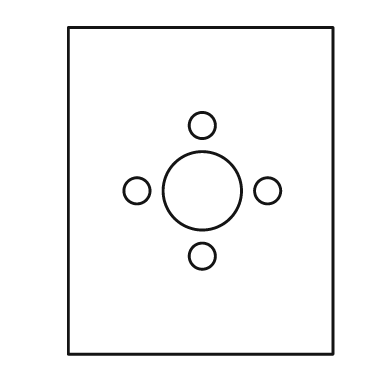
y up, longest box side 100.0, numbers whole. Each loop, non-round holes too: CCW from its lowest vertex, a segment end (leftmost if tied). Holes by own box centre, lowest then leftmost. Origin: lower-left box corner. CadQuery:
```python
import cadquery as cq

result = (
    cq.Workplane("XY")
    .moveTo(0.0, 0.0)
    .lineTo(81.0, 0.0)
    .lineTo(81.0, 100.0)
    .lineTo(0.0, 100.0)
    .close()
    .moveTo(41.0, 30.0)
    .circle(4.0)
    .moveTo(21.0, 50.0)
    .circle(4.0)
    .moveTo(41.0, 50.0)
    .circle(12.0)
    .moveTo(61.0, 50.0)
    .circle(4.0)
    .moveTo(41.0, 70.0)
    .circle(4.0)
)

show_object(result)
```